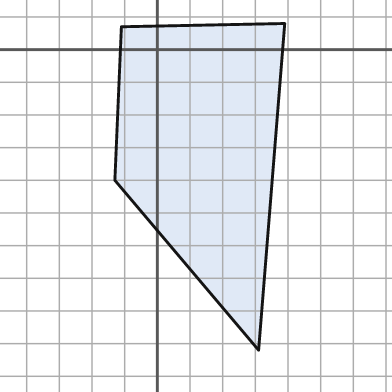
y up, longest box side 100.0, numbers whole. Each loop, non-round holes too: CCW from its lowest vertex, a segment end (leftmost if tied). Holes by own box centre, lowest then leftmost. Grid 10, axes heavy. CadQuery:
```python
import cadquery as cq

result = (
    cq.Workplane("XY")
    .moveTo(31.0, -92.0)
    .lineTo(39.0, 8.0)
    .lineTo(-11.0, 7.0)
    .lineTo(-13.0, -40.0)
    .close()
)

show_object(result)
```